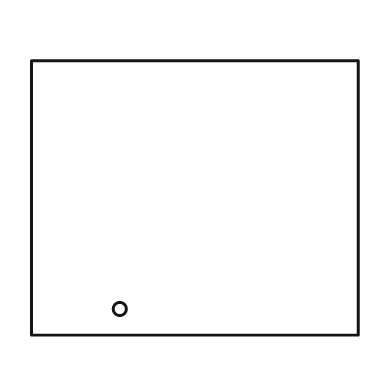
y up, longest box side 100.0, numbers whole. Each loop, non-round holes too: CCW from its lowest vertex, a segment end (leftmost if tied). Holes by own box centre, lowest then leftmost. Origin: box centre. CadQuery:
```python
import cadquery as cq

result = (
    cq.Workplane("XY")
    .moveTo(-50.0, -42.0)
    .lineTo(50.0, -42.0)
    .lineTo(50.0, 42.0)
    .lineTo(-50.0, 42.0)
    .close()
    .moveTo(-23.0, -34.0)
    .circle(2.0)
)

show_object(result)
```